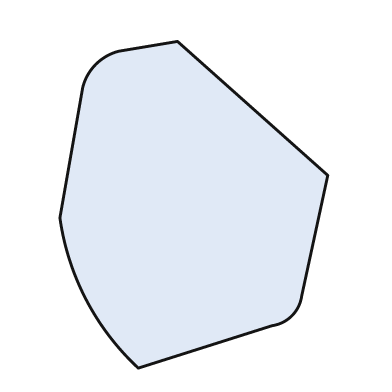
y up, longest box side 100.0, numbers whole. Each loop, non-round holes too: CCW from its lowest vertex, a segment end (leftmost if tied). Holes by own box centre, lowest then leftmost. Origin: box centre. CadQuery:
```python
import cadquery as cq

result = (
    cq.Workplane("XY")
    .moveTo(-17.0, -50.0)
    .lineTo(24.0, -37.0)
    .threePointArc((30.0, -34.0), (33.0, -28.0))
    .lineTo(41.0, 9.0)
    .lineTo(-5.0, 50.0)
    .lineTo(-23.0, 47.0)
    .threePointArc((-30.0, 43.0), (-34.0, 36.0))
    .lineTo(-41.0, -4.0)
    .threePointArc((-33.0, -29.0), (-17.0, -50.0))
    .close()
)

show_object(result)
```